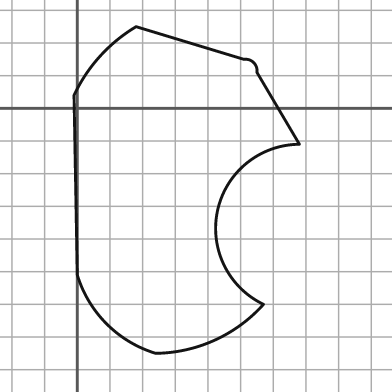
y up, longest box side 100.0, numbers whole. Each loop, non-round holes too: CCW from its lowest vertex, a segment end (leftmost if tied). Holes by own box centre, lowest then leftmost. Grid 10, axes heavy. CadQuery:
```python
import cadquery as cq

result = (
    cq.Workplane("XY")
    .moveTo(24.0, -75.0)
    .threePointArc((42.0, -71.0), (57.0, -60.0))
    .threePointArc((43.0, -31.0), (68.0, -11.0))
    .lineTo(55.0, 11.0)
    .threePointArc((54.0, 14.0), (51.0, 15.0))
    .lineTo(18.0, 25.0)
    .threePointArc((7.0, 16.0), (-1.0, 4.0))
    .lineTo(0.0, -51.0)
    .threePointArc((9.0, -66.0), (24.0, -75.0))
    .close()
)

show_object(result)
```